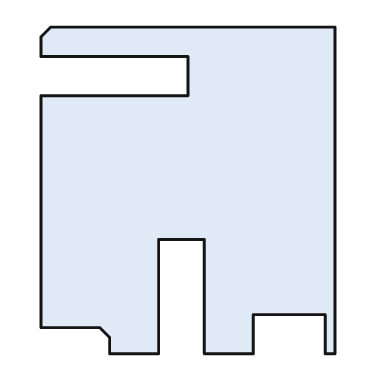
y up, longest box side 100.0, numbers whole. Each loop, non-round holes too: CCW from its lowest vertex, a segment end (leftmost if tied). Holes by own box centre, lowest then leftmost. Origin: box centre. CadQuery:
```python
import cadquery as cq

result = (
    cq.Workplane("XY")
    .moveTo(-24.0, -50.0)
    .lineTo(-9.0, -50.0)
    .lineTo(-9.0, -15.0)
    .lineTo(5.0, -15.0)
    .lineTo(5.0, -50.0)
    .lineTo(20.0, -50.0)
    .lineTo(20.0, -38.0)
    .lineTo(42.0, -38.0)
    .lineTo(42.0, -50.0)
    .lineTo(45.0, -50.0)
    .lineTo(45.0, 50.0)
    .lineTo(-42.0, 50.0)
    .lineTo(-45.0, 47.0)
    .lineTo(-45.0, 41.0)
    .lineTo(0.0, 41.0)
    .lineTo(0.0, 29.0)
    .lineTo(-45.0, 29.0)
    .lineTo(-45.0, -42.0)
    .lineTo(-27.0, -42.0)
    .lineTo(-24.0, -45.0)
    .close()
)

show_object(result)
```